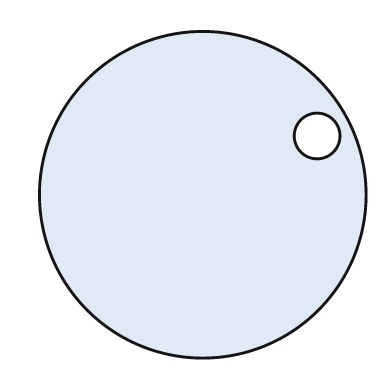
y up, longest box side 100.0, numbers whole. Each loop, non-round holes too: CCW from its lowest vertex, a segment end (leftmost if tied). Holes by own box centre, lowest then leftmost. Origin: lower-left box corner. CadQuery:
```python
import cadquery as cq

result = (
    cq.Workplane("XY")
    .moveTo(50.0, 50.0)
    .circle(50.0)
    .moveTo(85.0, 68.0)
    .circle(7.0)
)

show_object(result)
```